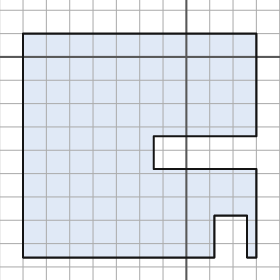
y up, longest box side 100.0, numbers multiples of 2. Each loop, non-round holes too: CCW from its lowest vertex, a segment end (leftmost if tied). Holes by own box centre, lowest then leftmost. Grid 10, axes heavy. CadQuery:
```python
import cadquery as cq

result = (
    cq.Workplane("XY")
    .moveTo(-70.0, -86.0)
    .lineTo(12.0, -86.0)
    .lineTo(12.0, -68.0)
    .lineTo(26.0, -68.0)
    .lineTo(26.0, -86.0)
    .lineTo(30.0, -86.0)
    .lineTo(30.0, -48.0)
    .lineTo(-14.0, -48.0)
    .lineTo(-14.0, -34.0)
    .lineTo(30.0, -34.0)
    .lineTo(30.0, 10.0)
    .lineTo(-70.0, 10.0)
    .close()
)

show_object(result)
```